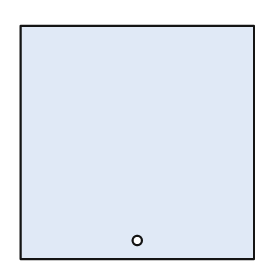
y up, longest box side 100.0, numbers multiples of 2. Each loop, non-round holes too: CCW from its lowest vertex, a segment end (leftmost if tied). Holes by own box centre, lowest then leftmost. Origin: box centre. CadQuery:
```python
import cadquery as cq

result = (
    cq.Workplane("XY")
    .moveTo(-50.0, -50.0)
    .lineTo(50.0, -50.0)
    .lineTo(50.0, 50.0)
    .lineTo(-50.0, 50.0)
    .close()
    .moveTo(0.0, -42.0)
    .circle(2.0)
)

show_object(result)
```